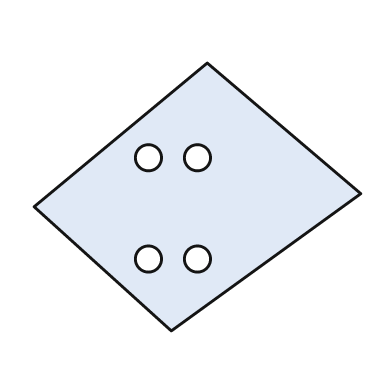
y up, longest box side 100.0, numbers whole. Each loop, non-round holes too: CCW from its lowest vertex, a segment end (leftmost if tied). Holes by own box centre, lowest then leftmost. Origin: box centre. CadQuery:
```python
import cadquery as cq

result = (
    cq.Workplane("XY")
    .moveTo(-8.0, -41.0)
    .lineTo(50.0, 1.0)
    .lineTo(3.0, 41.0)
    .lineTo(-50.0, -3.0)
    .close()
    .moveTo(-15.0, -19.0)
    .circle(4.0)
    .moveTo(0.0, -19.0)
    .circle(4.0)
    .moveTo(-15.0, 12.0)
    .circle(4.0)
    .moveTo(0.0, 12.0)
    .circle(4.0)
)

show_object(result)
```